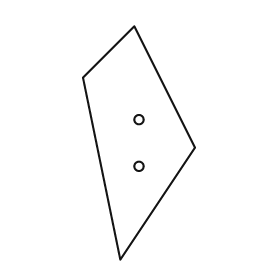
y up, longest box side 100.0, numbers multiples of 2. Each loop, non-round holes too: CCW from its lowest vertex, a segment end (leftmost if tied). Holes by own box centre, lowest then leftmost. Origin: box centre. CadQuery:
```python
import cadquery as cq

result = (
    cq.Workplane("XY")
    .moveTo(-8.0, -50.0)
    .lineTo(24.0, -2.0)
    .lineTo(-2.0, 50.0)
    .lineTo(-24.0, 28.0)
    .close()
    .moveTo(0.0, -10.0)
    .circle(2.0)
    .moveTo(0.0, 10.0)
    .circle(2.0)
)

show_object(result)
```